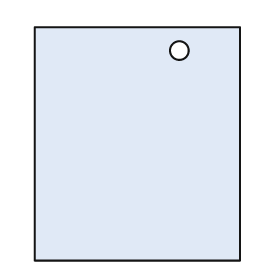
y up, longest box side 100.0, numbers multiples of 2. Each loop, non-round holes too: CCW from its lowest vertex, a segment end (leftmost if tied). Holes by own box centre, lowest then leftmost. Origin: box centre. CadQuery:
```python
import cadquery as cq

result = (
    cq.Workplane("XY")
    .moveTo(-44.0, -50.0)
    .lineTo(44.0, -50.0)
    .lineTo(44.0, 50.0)
    .lineTo(-44.0, 50.0)
    .close()
    .moveTo(18.0, 40.0)
    .circle(4.0)
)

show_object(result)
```